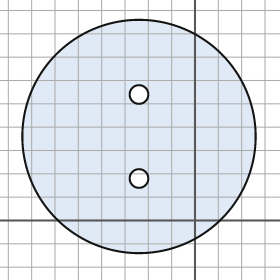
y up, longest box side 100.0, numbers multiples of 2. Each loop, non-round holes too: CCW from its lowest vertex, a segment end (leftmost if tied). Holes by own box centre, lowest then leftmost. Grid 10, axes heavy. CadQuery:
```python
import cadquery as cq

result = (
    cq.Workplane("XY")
    .moveTo(-24.0, 36.0)
    .circle(50.0)
    .moveTo(-24.0, 18.0)
    .circle(4.0)
    .moveTo(-24.0, 54.0)
    .circle(4.0)
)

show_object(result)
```